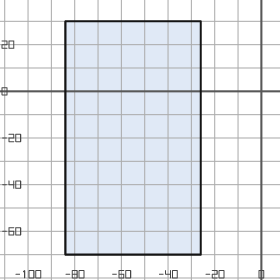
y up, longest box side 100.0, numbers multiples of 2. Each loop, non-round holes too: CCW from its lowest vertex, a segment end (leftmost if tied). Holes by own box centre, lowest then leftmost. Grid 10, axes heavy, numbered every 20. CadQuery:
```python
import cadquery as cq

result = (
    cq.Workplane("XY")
    .moveTo(-84.0, -70.0)
    .lineTo(-26.0, -70.0)
    .lineTo(-26.0, 30.0)
    .lineTo(-84.0, 30.0)
    .close()
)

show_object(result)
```